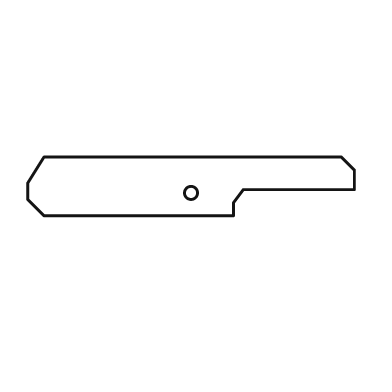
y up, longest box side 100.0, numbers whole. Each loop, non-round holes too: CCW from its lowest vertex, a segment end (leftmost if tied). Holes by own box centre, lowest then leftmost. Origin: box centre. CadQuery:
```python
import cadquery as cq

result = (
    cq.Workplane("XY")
    .moveTo(-45.0, -9.0)
    .lineTo(13.0, -9.0)
    .lineTo(13.0, -5.0)
    .lineTo(16.0, -1.0)
    .lineTo(50.0, -1.0)
    .lineTo(50.0, 5.0)
    .lineTo(46.0, 9.0)
    .lineTo(-45.0, 9.0)
    .lineTo(-50.0, 1.0)
    .lineTo(-50.0, -4.0)
    .close()
    .moveTo(0.0, -2.0)
    .circle(2.0)
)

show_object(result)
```